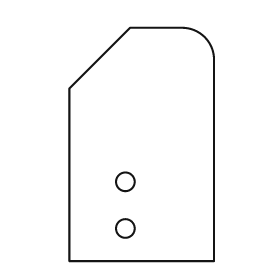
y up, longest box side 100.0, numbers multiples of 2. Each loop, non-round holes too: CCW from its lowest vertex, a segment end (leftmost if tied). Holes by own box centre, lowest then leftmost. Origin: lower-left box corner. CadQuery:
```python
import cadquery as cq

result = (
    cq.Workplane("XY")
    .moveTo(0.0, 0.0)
    .lineTo(62.0, 0.0)
    .lineTo(62.0, 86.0)
    .threePointArc((58.0, 96.0), (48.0, 100.0))
    .lineTo(26.0, 100.0)
    .lineTo(0.0, 74.0)
    .close()
    .moveTo(24.0, 14.0)
    .circle(4.0)
    .moveTo(24.0, 34.0)
    .circle(4.0)
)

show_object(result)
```